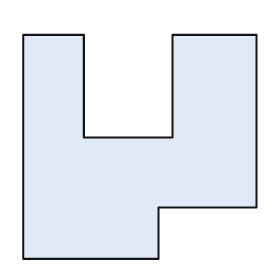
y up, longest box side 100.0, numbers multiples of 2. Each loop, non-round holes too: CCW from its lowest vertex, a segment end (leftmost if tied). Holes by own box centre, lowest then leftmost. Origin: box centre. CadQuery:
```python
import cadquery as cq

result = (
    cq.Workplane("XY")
    .moveTo(-50.0, -48.0)
    .lineTo(8.0, -48.0)
    .lineTo(8.0, -26.0)
    .lineTo(50.0, -26.0)
    .lineTo(50.0, 48.0)
    .lineTo(14.0, 48.0)
    .lineTo(14.0, 4.0)
    .lineTo(-24.0, 4.0)
    .lineTo(-24.0, 48.0)
    .lineTo(-50.0, 48.0)
    .close()
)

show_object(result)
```